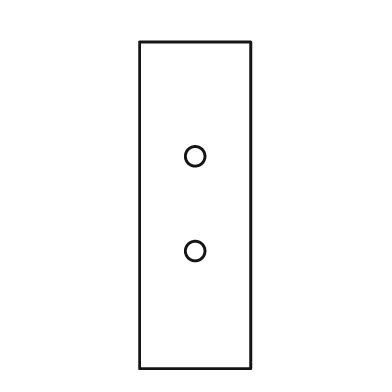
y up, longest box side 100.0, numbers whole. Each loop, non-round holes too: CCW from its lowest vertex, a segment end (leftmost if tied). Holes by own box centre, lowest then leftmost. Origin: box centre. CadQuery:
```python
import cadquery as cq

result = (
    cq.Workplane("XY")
    .moveTo(-17.0, -50.0)
    .lineTo(17.0, -50.0)
    .lineTo(17.0, 50.0)
    .lineTo(-17.0, 50.0)
    .close()
    .moveTo(0.0, -14.0)
    .circle(3.0)
    .moveTo(0.0, 15.0)
    .circle(3.0)
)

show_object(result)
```